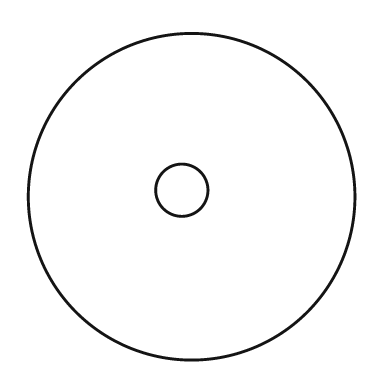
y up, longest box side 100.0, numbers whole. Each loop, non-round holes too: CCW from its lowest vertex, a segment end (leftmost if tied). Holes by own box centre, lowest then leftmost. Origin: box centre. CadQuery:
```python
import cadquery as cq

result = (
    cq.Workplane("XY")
    .moveTo(0.0, 0.0)
    .circle(50.0)
    .moveTo(-3.0, 2.0)
    .circle(8.0)
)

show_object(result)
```